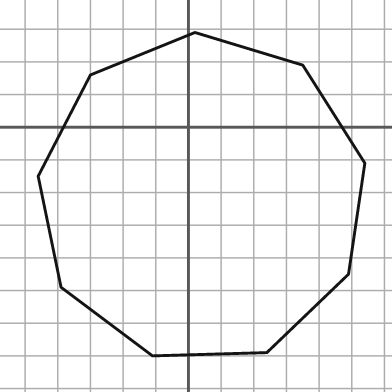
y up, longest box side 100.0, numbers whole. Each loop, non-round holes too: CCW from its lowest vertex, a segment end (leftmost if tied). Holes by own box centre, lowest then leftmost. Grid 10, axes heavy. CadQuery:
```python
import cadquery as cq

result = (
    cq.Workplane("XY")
    .moveTo(-11.0, -70.0)
    .lineTo(24.0, -69.0)
    .lineTo(49.0, -45.0)
    .lineTo(54.0, -11.0)
    .lineTo(35.0, 19.0)
    .lineTo(2.0, 29.0)
    .lineTo(-30.0, 16.0)
    .lineTo(-46.0, -15.0)
    .lineTo(-39.0, -49.0)
    .close()
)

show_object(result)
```